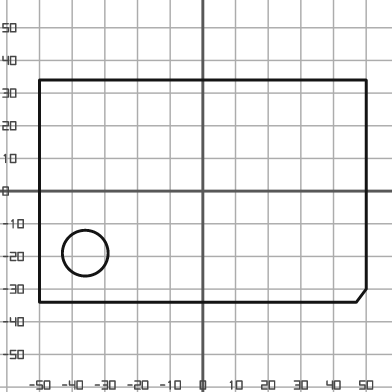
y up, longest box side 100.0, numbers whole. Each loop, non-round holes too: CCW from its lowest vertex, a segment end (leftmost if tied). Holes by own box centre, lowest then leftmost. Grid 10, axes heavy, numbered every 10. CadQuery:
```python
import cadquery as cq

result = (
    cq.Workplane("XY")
    .moveTo(-50.0, -34.0)
    .lineTo(47.0, -34.0)
    .lineTo(50.0, -30.0)
    .lineTo(50.0, 34.0)
    .lineTo(-50.0, 34.0)
    .close()
    .moveTo(-36.0, -19.0)
    .circle(7.0)
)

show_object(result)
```